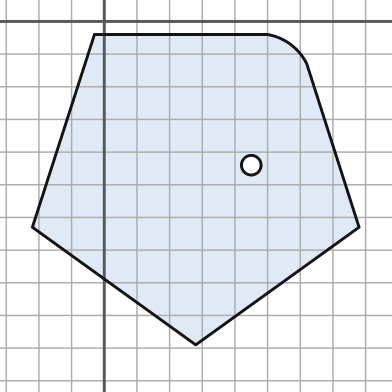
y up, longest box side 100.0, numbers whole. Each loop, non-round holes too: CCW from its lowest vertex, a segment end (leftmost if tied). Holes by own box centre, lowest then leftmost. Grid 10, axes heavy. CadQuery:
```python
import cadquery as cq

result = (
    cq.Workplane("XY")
    .moveTo(28.0, -99.0)
    .lineTo(78.0, -63.0)
    .lineTo(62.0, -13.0)
    .threePointArc((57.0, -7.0), (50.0, -4.0))
    .lineTo(-3.0, -4.0)
    .lineTo(-22.0, -63.0)
    .close()
    .moveTo(45.0, -44.0)
    .circle(3.0)
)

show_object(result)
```